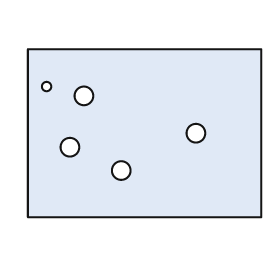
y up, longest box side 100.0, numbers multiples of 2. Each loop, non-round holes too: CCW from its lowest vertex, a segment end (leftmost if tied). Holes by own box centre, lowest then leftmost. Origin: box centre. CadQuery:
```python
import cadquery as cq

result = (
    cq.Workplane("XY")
    .moveTo(-50.0, -36.0)
    .lineTo(50.0, -36.0)
    .lineTo(50.0, 36.0)
    .lineTo(-50.0, 36.0)
    .close()
    .moveTo(-10.0, -16.0)
    .circle(4.0)
    .moveTo(-32.0, -6.0)
    .circle(4.0)
    .moveTo(22.0, 0.0)
    .circle(4.0)
    .moveTo(-26.0, 16.0)
    .circle(4.0)
    .moveTo(-42.0, 20.0)
    .circle(2.0)
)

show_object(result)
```